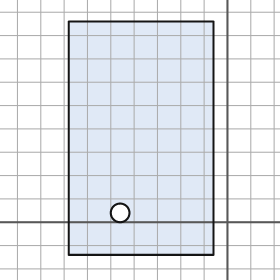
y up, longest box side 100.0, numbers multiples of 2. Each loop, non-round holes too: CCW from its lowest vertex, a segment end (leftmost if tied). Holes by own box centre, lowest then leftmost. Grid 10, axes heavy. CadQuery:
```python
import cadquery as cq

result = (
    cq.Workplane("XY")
    .moveTo(-68.0, -14.0)
    .lineTo(-6.0, -14.0)
    .lineTo(-6.0, 86.0)
    .lineTo(-68.0, 86.0)
    .close()
    .moveTo(-46.0, 4.0)
    .circle(4.0)
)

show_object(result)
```